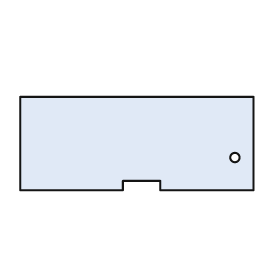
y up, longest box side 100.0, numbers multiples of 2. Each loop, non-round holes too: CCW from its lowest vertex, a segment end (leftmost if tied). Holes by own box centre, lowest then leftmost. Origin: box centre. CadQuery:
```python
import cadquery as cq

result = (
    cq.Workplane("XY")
    .moveTo(-50.0, -20.0)
    .lineTo(-6.0, -20.0)
    .lineTo(-6.0, -16.0)
    .lineTo(10.0, -16.0)
    .lineTo(10.0, -20.0)
    .lineTo(50.0, -20.0)
    .lineTo(50.0, 20.0)
    .lineTo(-50.0, 20.0)
    .close()
    .moveTo(42.0, -6.0)
    .circle(2.0)
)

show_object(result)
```